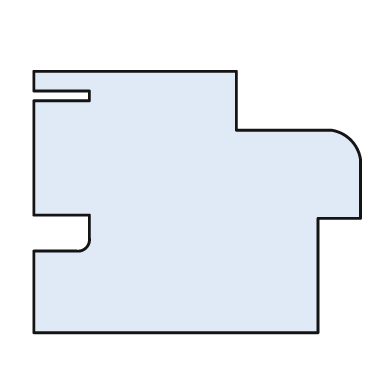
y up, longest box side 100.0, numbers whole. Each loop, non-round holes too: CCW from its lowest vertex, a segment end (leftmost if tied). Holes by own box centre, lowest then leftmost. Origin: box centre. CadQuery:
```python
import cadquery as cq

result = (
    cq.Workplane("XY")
    .moveTo(-50.0, -40.0)
    .lineTo(37.0, -40.0)
    .lineTo(37.0, -5.0)
    .lineTo(50.0, -5.0)
    .lineTo(50.0, 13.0)
    .threePointArc((47.0, 19.0), (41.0, 22.0))
    .lineTo(12.0, 22.0)
    .lineTo(12.0, 40.0)
    .lineTo(-50.0, 40.0)
    .lineTo(-50.0, 34.0)
    .lineTo(-33.0, 34.0)
    .lineTo(-33.0, 31.0)
    .lineTo(-50.0, 31.0)
    .lineTo(-50.0, -4.0)
    .lineTo(-33.0, -4.0)
    .lineTo(-33.0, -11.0)
    .threePointArc((-34.0, -14.0), (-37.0, -15.0))
    .lineTo(-50.0, -15.0)
    .close()
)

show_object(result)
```